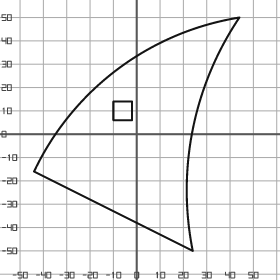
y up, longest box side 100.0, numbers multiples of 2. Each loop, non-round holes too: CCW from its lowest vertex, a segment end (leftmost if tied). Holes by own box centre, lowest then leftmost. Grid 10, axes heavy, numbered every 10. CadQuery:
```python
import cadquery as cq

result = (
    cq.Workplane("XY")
    .moveTo(24.0, -50.0)
    .threePointArc((24.0, 2.0), (44.0, 50.0))
    .threePointArc((-8.0, 28.0), (-44.0, -16.0))
    .close()
    .moveTo(-10.0, 6.0)
    .lineTo(-2.0, 6.0)
    .lineTo(-2.0, 14.0)
    .lineTo(-10.0, 14.0)
    .close()
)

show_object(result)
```